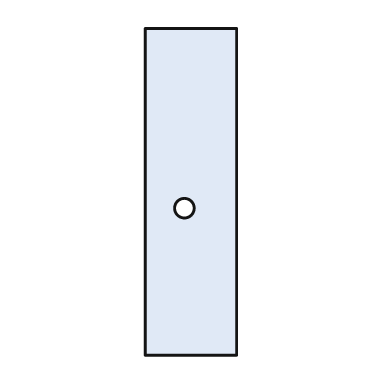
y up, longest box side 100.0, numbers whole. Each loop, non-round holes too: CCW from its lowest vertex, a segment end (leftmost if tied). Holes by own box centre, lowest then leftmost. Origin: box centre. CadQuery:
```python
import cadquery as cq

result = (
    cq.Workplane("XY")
    .moveTo(-14.0, -50.0)
    .lineTo(14.0, -50.0)
    .lineTo(14.0, 50.0)
    .lineTo(-14.0, 50.0)
    .close()
    .moveTo(-2.0, -5.0)
    .circle(3.0)
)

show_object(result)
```